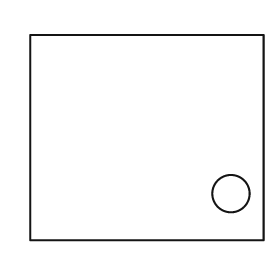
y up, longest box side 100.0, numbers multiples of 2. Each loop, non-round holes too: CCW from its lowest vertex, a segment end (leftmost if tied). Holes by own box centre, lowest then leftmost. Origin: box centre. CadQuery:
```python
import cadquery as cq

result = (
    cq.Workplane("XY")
    .moveTo(-50.0, -44.0)
    .lineTo(50.0, -44.0)
    .lineTo(50.0, 44.0)
    .lineTo(-50.0, 44.0)
    .close()
    .moveTo(36.0, -24.0)
    .circle(8.0)
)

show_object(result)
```